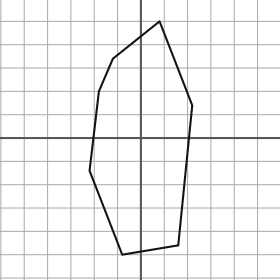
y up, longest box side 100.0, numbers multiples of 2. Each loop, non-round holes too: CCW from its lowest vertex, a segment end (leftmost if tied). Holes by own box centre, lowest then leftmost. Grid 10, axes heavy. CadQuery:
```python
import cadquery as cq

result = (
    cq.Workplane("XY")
    .moveTo(-8.0, -50.0)
    .lineTo(16.0, -46.0)
    .lineTo(22.0, 14.0)
    .lineTo(8.0, 50.0)
    .lineTo(-12.0, 34.0)
    .lineTo(-18.0, 20.0)
    .lineTo(-22.0, -14.0)
    .close()
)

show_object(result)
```